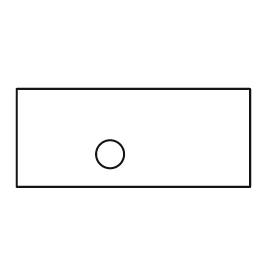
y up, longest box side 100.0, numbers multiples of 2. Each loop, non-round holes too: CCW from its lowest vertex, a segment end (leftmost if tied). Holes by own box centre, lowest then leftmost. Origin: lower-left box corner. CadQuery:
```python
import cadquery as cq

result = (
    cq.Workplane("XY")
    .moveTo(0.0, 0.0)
    .lineTo(100.0, 0.0)
    .lineTo(100.0, 42.0)
    .lineTo(0.0, 42.0)
    .close()
    .moveTo(40.0, 14.0)
    .circle(6.0)
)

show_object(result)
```